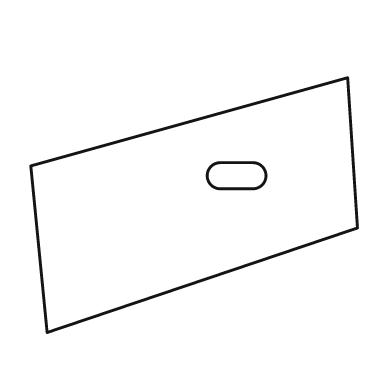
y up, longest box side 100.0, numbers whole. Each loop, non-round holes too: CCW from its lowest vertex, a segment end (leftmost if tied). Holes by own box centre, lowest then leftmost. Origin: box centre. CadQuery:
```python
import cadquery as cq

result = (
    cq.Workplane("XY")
    .moveTo(-45.0, -39.0)
    .lineTo(50.0, -7.0)
    .lineTo(47.0, 39.0)
    .lineTo(-50.0, 12.0)
    .close()
    .moveTo(8.0, 5.0)
    .lineTo(18.0, 5.0)
    .threePointArc((22.0, 9.0), (18.0, 13.0))
    .lineTo(8.0, 13.0)
    .threePointArc((4.0, 9.0), (8.0, 5.0))
    .close()
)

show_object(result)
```